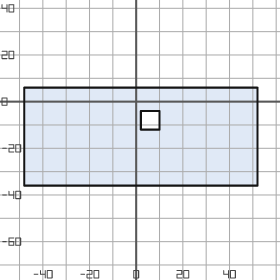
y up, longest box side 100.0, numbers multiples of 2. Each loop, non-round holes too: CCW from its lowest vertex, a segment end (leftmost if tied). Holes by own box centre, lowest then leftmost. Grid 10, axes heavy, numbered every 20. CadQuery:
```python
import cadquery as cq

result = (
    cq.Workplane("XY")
    .moveTo(-48.0, -36.0)
    .lineTo(52.0, -36.0)
    .lineTo(52.0, 6.0)
    .lineTo(-48.0, 6.0)
    .close()
    .moveTo(2.0, -12.0)
    .lineTo(10.0, -12.0)
    .lineTo(10.0, -4.0)
    .lineTo(2.0, -4.0)
    .close()
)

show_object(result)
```